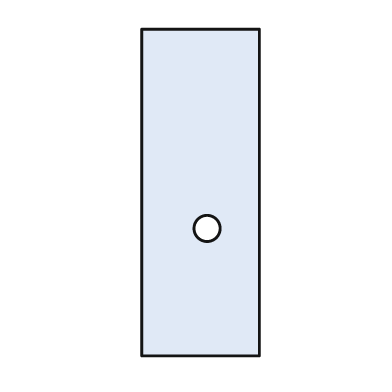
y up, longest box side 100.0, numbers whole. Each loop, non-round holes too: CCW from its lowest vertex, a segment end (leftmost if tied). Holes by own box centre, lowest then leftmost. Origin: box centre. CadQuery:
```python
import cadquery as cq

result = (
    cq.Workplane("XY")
    .moveTo(-18.0, -50.0)
    .lineTo(18.0, -50.0)
    .lineTo(18.0, 50.0)
    .lineTo(-18.0, 50.0)
    .close()
    .moveTo(2.0, -11.0)
    .circle(4.0)
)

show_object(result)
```